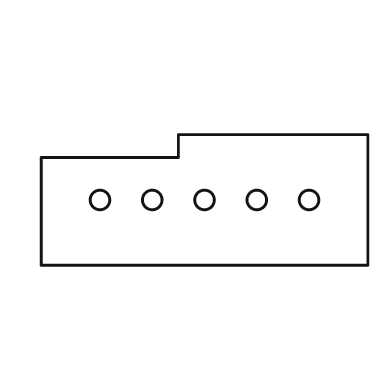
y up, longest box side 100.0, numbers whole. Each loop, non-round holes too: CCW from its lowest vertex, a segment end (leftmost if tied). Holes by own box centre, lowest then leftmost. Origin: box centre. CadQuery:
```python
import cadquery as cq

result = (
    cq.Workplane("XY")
    .moveTo(-50.0, -20.0)
    .lineTo(50.0, -20.0)
    .lineTo(50.0, 20.0)
    .lineTo(-8.0, 20.0)
    .lineTo(-8.0, 13.0)
    .lineTo(-50.0, 13.0)
    .close()
    .moveTo(-32.0, 0.0)
    .circle(3.0)
    .moveTo(-16.0, 0.0)
    .circle(3.0)
    .moveTo(0.0, 0.0)
    .circle(3.0)
    .moveTo(16.0, 0.0)
    .circle(3.0)
    .moveTo(32.0, 0.0)
    .circle(3.0)
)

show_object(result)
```